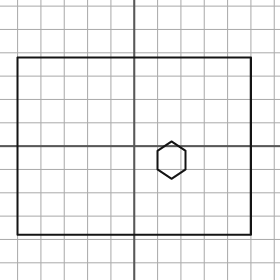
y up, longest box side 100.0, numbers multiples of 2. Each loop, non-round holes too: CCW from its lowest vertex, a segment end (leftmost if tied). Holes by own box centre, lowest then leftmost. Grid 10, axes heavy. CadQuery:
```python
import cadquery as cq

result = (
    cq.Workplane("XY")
    .moveTo(-50.0, -38.0)
    .lineTo(50.0, -38.0)
    .lineTo(50.0, 38.0)
    .lineTo(-50.0, 38.0)
    .close()
    .moveTo(16.0, -14.0)
    .lineTo(22.0, -10.0)
    .lineTo(22.0, -2.0)
    .lineTo(16.0, 2.0)
    .lineTo(10.0, -2.0)
    .lineTo(10.0, -10.0)
    .close()
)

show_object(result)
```